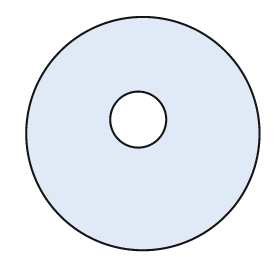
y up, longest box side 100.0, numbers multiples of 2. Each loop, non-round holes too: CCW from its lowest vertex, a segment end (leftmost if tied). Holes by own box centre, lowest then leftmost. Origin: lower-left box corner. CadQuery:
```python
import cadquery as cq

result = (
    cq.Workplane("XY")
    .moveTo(50.0, 50.0)
    .circle(50.0)
    .moveTo(48.0, 56.0)
    .circle(12.0)
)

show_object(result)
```